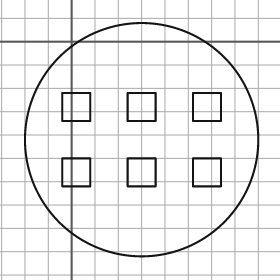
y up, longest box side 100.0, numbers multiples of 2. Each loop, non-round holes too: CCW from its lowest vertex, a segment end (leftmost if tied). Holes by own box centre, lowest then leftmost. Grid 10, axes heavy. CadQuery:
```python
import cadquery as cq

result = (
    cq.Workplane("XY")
    .moveTo(30.0, -42.0)
    .circle(50.0)
    .moveTo(-4.0, -62.0)
    .lineTo(8.0, -62.0)
    .lineTo(8.0, -50.0)
    .lineTo(-4.0, -50.0)
    .close()
    .moveTo(24.0, -62.0)
    .lineTo(36.0, -62.0)
    .lineTo(36.0, -50.0)
    .lineTo(24.0, -50.0)
    .close()
    .moveTo(52.0, -62.0)
    .lineTo(64.0, -62.0)
    .lineTo(64.0, -50.0)
    .lineTo(52.0, -50.0)
    .close()
    .moveTo(-4.0, -34.0)
    .lineTo(8.0, -34.0)
    .lineTo(8.0, -22.0)
    .lineTo(-4.0, -22.0)
    .close()
    .moveTo(24.0, -34.0)
    .lineTo(36.0, -34.0)
    .lineTo(36.0, -22.0)
    .lineTo(24.0, -22.0)
    .close()
    .moveTo(52.0, -34.0)
    .lineTo(64.0, -34.0)
    .lineTo(64.0, -22.0)
    .lineTo(52.0, -22.0)
    .close()
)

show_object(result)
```